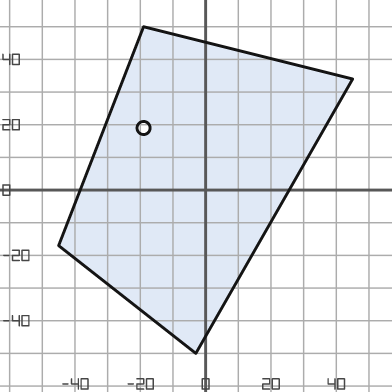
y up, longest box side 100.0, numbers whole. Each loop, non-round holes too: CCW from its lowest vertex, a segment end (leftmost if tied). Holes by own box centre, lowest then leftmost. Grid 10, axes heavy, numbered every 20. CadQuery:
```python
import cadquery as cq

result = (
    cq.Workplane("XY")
    .moveTo(-3.0, -50.0)
    .lineTo(45.0, 34.0)
    .lineTo(-19.0, 50.0)
    .lineTo(-45.0, -17.0)
    .close()
    .moveTo(-19.0, 19.0)
    .circle(2.0)
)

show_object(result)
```